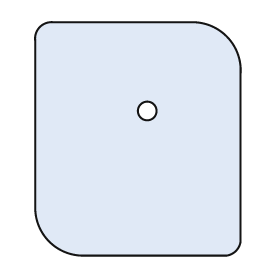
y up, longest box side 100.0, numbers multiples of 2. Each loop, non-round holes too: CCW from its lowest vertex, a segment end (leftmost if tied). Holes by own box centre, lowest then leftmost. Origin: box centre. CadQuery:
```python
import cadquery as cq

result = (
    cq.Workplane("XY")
    .moveTo(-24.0, -50.0)
    .lineTo(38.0, -50.0)
    .threePointArc((42.0, -48.0), (44.0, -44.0))
    .lineTo(44.0, 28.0)
    .threePointArc((38.0, 44.0), (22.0, 50.0))
    .lineTo(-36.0, 50.0)
    .threePointArc((-42.0, 48.0), (-44.0, 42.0))
    .lineTo(-44.0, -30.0)
    .threePointArc((-38.0, -44.0), (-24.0, -50.0))
    .close()
    .moveTo(4.0, 12.0)
    .circle(4.0)
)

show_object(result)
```